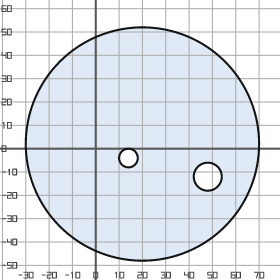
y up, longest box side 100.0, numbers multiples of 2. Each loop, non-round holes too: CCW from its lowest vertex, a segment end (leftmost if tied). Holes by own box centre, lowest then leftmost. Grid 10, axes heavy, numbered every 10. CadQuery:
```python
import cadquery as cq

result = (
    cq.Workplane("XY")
    .moveTo(20.0, 2.0)
    .circle(50.0)
    .moveTo(48.0, -12.0)
    .circle(6.0)
    .moveTo(14.0, -4.0)
    .circle(4.0)
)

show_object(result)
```